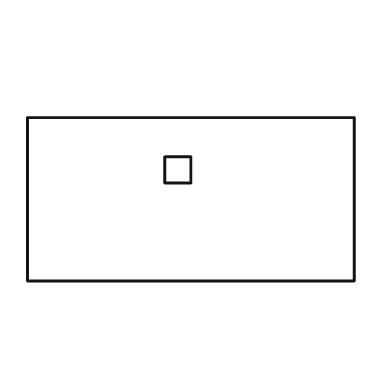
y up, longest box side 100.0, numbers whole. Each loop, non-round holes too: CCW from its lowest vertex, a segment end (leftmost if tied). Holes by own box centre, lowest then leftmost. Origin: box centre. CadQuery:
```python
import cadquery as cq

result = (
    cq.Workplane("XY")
    .moveTo(-50.0, -25.0)
    .lineTo(50.0, -25.0)
    .lineTo(50.0, 25.0)
    .lineTo(-50.0, 25.0)
    .close()
    .moveTo(-8.0, 5.0)
    .lineTo(0.0, 5.0)
    .lineTo(0.0, 13.0)
    .lineTo(-8.0, 13.0)
    .close()
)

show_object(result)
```